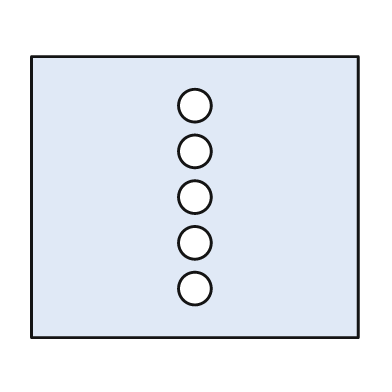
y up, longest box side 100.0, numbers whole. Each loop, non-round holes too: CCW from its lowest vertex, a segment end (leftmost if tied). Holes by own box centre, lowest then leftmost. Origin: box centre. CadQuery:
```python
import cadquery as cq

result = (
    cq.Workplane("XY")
    .moveTo(-50.0, -43.0)
    .lineTo(50.0, -43.0)
    .lineTo(50.0, 43.0)
    .lineTo(-50.0, 43.0)
    .close()
    .moveTo(0.0, -28.0)
    .circle(5.0)
    .moveTo(0.0, -14.0)
    .circle(5.0)
    .moveTo(0.0, 0.0)
    .circle(5.0)
    .moveTo(0.0, 14.0)
    .circle(5.0)
    .moveTo(0.0, 28.0)
    .circle(5.0)
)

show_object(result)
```